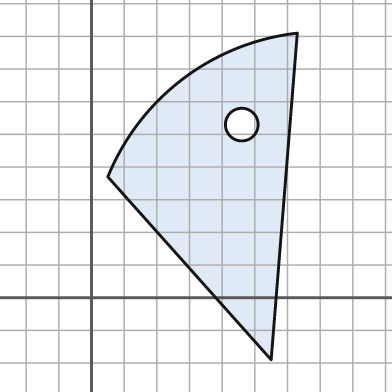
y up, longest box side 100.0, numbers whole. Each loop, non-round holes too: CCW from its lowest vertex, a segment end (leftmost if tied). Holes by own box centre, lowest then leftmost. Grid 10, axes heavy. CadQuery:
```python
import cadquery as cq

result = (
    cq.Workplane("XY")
    .moveTo(55.0, -19.0)
    .lineTo(63.0, 81.0)
    .threePointArc((28.0, 67.0), (5.0, 37.0))
    .close()
    .moveTo(46.0, 53.0)
    .circle(5.0)
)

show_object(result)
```